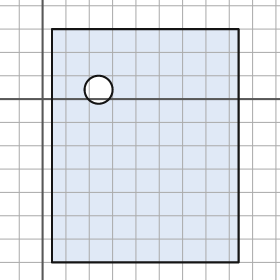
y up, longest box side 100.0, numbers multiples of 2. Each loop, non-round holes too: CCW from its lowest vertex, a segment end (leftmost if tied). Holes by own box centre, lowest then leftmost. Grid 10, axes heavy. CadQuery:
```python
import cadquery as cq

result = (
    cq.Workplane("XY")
    .moveTo(4.0, -70.0)
    .lineTo(84.0, -70.0)
    .lineTo(84.0, 30.0)
    .lineTo(4.0, 30.0)
    .close()
    .moveTo(24.0, 4.0)
    .circle(6.0)
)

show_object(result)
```